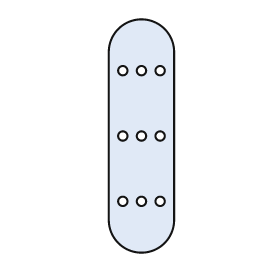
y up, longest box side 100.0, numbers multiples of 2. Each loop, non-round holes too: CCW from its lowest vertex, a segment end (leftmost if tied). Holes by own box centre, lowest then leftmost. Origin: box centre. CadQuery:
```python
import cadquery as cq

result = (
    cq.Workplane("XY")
    .moveTo(-14.0, -36.0)
    .threePointArc((0.0, -50.0), (14.0, -36.0))
    .lineTo(14.0, 36.0)
    .threePointArc((0.0, 50.0), (-14.0, 36.0))
    .close()
    .moveTo(-8.0, -28.0)
    .circle(2.0)
    .moveTo(0.0, -28.0)
    .circle(2.0)
    .moveTo(8.0, -28.0)
    .circle(2.0)
    .moveTo(-8.0, 0.0)
    .circle(2.0)
    .moveTo(0.0, 0.0)
    .circle(2.0)
    .moveTo(8.0, 0.0)
    .circle(2.0)
    .moveTo(-8.0, 28.0)
    .circle(2.0)
    .moveTo(0.0, 28.0)
    .circle(2.0)
    .moveTo(8.0, 28.0)
    .circle(2.0)
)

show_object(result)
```